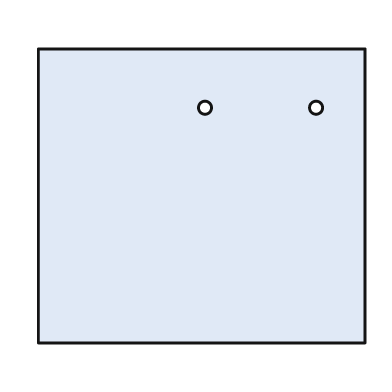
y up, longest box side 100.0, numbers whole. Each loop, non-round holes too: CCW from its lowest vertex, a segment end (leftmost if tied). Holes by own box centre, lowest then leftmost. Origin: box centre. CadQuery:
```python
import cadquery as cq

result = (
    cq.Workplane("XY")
    .moveTo(-50.0, -45.0)
    .lineTo(50.0, -45.0)
    .lineTo(50.0, 45.0)
    .lineTo(-50.0, 45.0)
    .close()
    .moveTo(1.0, 27.0)
    .circle(2.0)
    .moveTo(35.0, 27.0)
    .circle(2.0)
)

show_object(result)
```